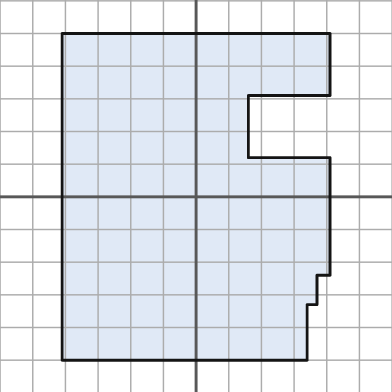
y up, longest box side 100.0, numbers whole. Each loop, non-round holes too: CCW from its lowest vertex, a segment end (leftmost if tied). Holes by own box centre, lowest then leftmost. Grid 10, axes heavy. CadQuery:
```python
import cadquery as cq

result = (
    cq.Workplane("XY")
    .moveTo(-41.0, -50.0)
    .lineTo(34.0, -50.0)
    .lineTo(34.0, -33.0)
    .lineTo(37.0, -33.0)
    .lineTo(37.0, -24.0)
    .lineTo(41.0, -24.0)
    .lineTo(41.0, 12.0)
    .lineTo(16.0, 12.0)
    .lineTo(16.0, 31.0)
    .lineTo(41.0, 31.0)
    .lineTo(41.0, 50.0)
    .lineTo(-41.0, 50.0)
    .close()
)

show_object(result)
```